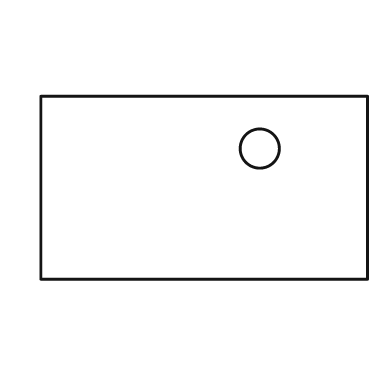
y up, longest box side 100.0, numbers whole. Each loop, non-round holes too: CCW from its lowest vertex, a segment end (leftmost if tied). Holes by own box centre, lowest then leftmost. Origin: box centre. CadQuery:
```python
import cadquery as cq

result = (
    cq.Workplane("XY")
    .moveTo(-50.0, -28.0)
    .lineTo(50.0, -28.0)
    .lineTo(50.0, 28.0)
    .lineTo(-50.0, 28.0)
    .close()
    .moveTo(17.0, 12.0)
    .circle(6.0)
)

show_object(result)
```